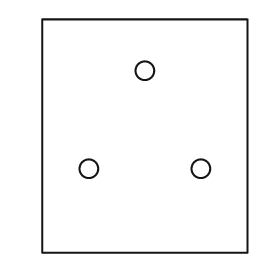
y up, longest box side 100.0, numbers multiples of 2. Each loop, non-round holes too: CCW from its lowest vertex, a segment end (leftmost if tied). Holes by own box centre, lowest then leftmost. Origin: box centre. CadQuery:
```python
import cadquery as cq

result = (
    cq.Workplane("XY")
    .moveTo(-44.0, -50.0)
    .lineTo(44.0, -50.0)
    .lineTo(44.0, 50.0)
    .lineTo(-44.0, 50.0)
    .close()
    .moveTo(-24.0, -14.0)
    .circle(4.0)
    .moveTo(24.0, -14.0)
    .circle(4.0)
    .moveTo(0.0, 28.0)
    .circle(4.0)
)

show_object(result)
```